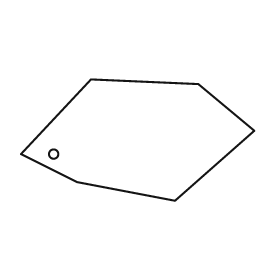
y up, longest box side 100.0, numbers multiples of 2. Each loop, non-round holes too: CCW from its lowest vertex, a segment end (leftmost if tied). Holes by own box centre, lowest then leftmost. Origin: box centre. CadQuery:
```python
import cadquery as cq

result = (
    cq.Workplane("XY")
    .moveTo(16.0, -26.0)
    .lineTo(50.0, 4.0)
    .lineTo(26.0, 24.0)
    .lineTo(-20.0, 26.0)
    .lineTo(-50.0, -6.0)
    .lineTo(-26.0, -18.0)
    .close()
    .moveTo(-36.0, -6.0)
    .circle(2.0)
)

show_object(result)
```